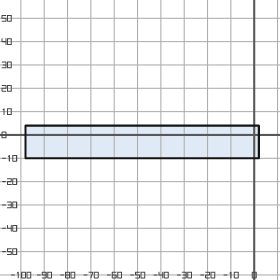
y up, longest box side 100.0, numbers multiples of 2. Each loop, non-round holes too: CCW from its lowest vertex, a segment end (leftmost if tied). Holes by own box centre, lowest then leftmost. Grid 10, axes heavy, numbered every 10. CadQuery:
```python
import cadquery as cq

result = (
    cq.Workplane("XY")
    .moveTo(-98.0, -10.0)
    .lineTo(2.0, -10.0)
    .lineTo(2.0, 4.0)
    .lineTo(-98.0, 4.0)
    .close()
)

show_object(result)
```